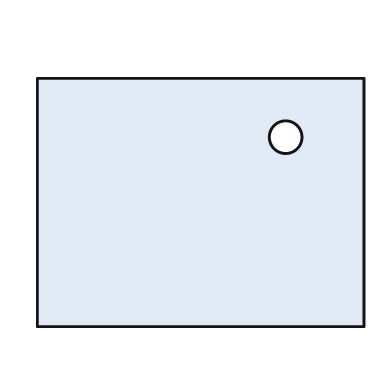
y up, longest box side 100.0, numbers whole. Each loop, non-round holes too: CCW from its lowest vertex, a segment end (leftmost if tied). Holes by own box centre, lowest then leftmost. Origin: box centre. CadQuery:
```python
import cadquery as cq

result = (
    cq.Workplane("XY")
    .moveTo(-50.0, -38.0)
    .lineTo(50.0, -38.0)
    .lineTo(50.0, 38.0)
    .lineTo(-50.0, 38.0)
    .close()
    .moveTo(26.0, 20.0)
    .circle(5.0)
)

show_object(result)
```